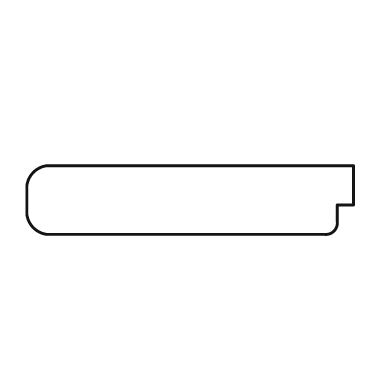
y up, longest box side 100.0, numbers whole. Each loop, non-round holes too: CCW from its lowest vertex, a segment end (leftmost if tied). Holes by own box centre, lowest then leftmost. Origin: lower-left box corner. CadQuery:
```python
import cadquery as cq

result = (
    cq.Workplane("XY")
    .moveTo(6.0, 0.0)
    .lineTo(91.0, 0.0)
    .threePointArc((94.0, 1.0), (95.0, 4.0))
    .lineTo(95.0, 9.0)
    .lineTo(100.0, 9.0)
    .lineTo(100.0, 21.0)
    .lineTo(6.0, 21.0)
    .threePointArc((2.0, 19.0), (0.0, 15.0))
    .lineTo(0.0, 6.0)
    .threePointArc((2.0, 2.0), (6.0, 0.0))
    .close()
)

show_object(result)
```